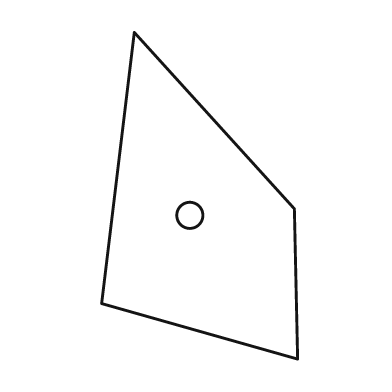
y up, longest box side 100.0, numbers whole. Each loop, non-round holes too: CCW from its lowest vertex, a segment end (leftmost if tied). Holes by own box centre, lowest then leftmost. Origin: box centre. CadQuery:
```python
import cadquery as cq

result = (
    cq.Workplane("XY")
    .moveTo(30.0, -50.0)
    .lineTo(29.0, -4.0)
    .lineTo(-20.0, 50.0)
    .lineTo(-30.0, -33.0)
    .close()
    .moveTo(-3.0, -6.0)
    .circle(4.0)
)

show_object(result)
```